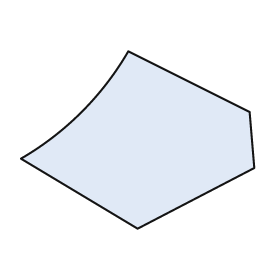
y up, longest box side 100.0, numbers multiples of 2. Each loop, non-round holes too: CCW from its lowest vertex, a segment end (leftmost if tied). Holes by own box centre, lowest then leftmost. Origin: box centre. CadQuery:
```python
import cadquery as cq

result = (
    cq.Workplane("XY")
    .moveTo(0.0, -38.0)
    .lineTo(50.0, -12.0)
    .lineTo(48.0, 12.0)
    .lineTo(-4.0, 38.0)
    .threePointArc((-24.0, 12.0), (-50.0, -8.0))
    .close()
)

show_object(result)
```